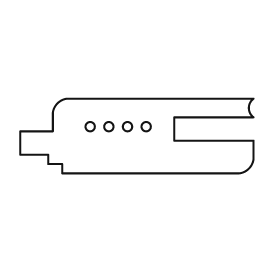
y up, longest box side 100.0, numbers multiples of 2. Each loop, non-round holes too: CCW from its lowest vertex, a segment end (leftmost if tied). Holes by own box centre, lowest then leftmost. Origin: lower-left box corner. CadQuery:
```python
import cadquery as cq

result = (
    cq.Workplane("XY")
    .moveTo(18.0, 0.0)
    .lineTo(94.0, 0.0)
    .threePointArc((98.0, 2.0), (100.0, 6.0))
    .lineTo(100.0, 14.0)
    .lineTo(66.0, 14.0)
    .lineTo(66.0, 24.0)
    .lineTo(100.0, 24.0)
    .threePointArc((98.0, 28.0), (100.0, 32.0))
    .lineTo(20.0, 32.0)
    .threePointArc((16.0, 30.0), (14.0, 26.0))
    .lineTo(14.0, 18.0)
    .lineTo(0.0, 18.0)
    .lineTo(0.0, 8.0)
    .lineTo(12.0, 8.0)
    .lineTo(12.0, 4.0)
    .lineTo(18.0, 4.0)
    .close()
    .moveTo(30.0, 20.0)
    .circle(2.0)
    .moveTo(38.0, 20.0)
    .circle(2.0)
    .moveTo(46.0, 20.0)
    .circle(2.0)
    .moveTo(54.0, 20.0)
    .circle(2.0)
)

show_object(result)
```